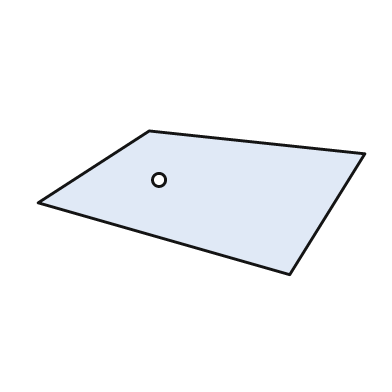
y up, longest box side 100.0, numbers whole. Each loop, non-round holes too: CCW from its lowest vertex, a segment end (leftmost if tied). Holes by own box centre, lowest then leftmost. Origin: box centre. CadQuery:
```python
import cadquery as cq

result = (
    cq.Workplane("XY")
    .moveTo(27.0, -22.0)
    .lineTo(50.0, 15.0)
    .lineTo(-16.0, 22.0)
    .lineTo(-50.0, 0.0)
    .close()
    .moveTo(-13.0, 7.0)
    .circle(2.0)
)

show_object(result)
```